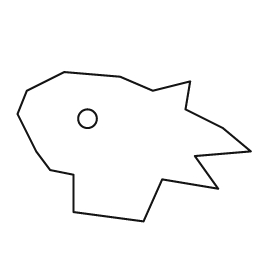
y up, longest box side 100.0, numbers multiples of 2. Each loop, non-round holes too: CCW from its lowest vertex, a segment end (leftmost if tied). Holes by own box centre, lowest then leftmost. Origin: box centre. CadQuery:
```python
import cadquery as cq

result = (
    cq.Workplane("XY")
    .moveTo(4.0, -32.0)
    .lineTo(12.0, -14.0)
    .lineTo(36.0, -18.0)
    .lineTo(26.0, -4.0)
    .lineTo(50.0, -2.0)
    .lineTo(38.0, 8.0)
    .lineTo(22.0, 16.0)
    .lineTo(24.0, 28.0)
    .lineTo(8.0, 24.0)
    .lineTo(-6.0, 30.0)
    .lineTo(-30.0, 32.0)
    .lineTo(-46.0, 24.0)
    .lineTo(-50.0, 14.0)
    .lineTo(-42.0, -2.0)
    .lineTo(-36.0, -10.0)
    .lineTo(-26.0, -12.0)
    .lineTo(-26.0, -28.0)
    .close()
    .moveTo(-20.0, 12.0)
    .circle(4.0)
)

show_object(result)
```